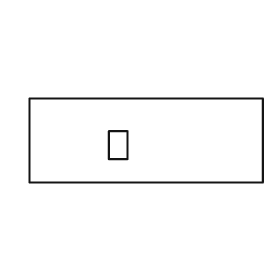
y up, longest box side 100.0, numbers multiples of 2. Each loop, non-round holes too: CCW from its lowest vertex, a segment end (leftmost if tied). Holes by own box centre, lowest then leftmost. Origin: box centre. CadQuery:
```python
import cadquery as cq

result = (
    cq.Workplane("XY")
    .moveTo(-50.0, -18.0)
    .lineTo(50.0, -18.0)
    .lineTo(50.0, 18.0)
    .lineTo(-50.0, 18.0)
    .close()
    .moveTo(-16.0, -8.0)
    .lineTo(-8.0, -8.0)
    .lineTo(-8.0, 4.0)
    .lineTo(-16.0, 4.0)
    .close()
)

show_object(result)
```